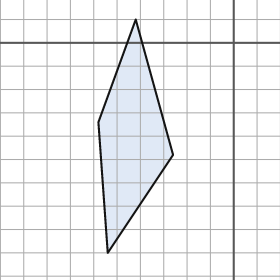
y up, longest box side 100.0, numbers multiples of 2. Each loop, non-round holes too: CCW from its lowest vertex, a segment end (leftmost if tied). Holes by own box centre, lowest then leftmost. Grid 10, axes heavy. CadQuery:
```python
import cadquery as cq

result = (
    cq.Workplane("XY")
    .moveTo(-54.0, -90.0)
    .lineTo(-26.0, -48.0)
    .lineTo(-42.0, 10.0)
    .lineTo(-58.0, -34.0)
    .close()
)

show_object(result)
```